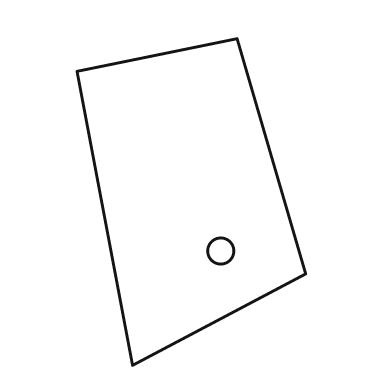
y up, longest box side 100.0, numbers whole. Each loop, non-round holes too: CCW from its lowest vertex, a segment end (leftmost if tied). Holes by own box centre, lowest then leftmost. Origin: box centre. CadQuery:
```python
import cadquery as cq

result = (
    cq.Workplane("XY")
    .moveTo(-18.0, -50.0)
    .lineTo(35.0, -22.0)
    .lineTo(14.0, 50.0)
    .lineTo(-35.0, 40.0)
    .close()
    .moveTo(9.0, -15.0)
    .circle(4.0)
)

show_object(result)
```